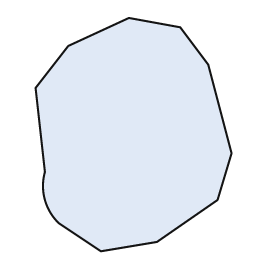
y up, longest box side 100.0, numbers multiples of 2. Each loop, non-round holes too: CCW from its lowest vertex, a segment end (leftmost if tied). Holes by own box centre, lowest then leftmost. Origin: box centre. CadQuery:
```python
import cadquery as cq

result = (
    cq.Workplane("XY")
    .moveTo(-14.0, -50.0)
    .lineTo(10.0, -46.0)
    .lineTo(36.0, -28.0)
    .lineTo(42.0, -8.0)
    .lineTo(32.0, 30.0)
    .lineTo(20.0, 46.0)
    .lineTo(-2.0, 50.0)
    .lineTo(-28.0, 38.0)
    .lineTo(-42.0, 20.0)
    .lineTo(-38.0, -16.0)
    .threePointArc((-38.0, -28.0), (-32.0, -38.0))
    .close()
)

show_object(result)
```